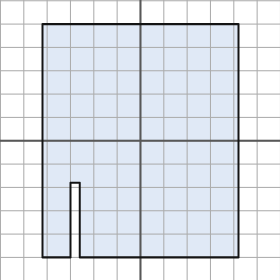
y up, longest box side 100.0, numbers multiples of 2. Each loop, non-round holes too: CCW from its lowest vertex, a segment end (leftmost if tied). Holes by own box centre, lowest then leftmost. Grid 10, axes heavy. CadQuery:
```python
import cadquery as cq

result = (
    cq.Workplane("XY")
    .moveTo(-42.0, -50.0)
    .lineTo(-30.0, -50.0)
    .lineTo(-30.0, -18.0)
    .lineTo(-26.0, -18.0)
    .lineTo(-26.0, -50.0)
    .lineTo(42.0, -50.0)
    .lineTo(42.0, 50.0)
    .lineTo(-42.0, 50.0)
    .close()
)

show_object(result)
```